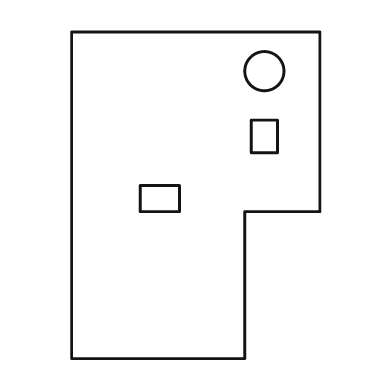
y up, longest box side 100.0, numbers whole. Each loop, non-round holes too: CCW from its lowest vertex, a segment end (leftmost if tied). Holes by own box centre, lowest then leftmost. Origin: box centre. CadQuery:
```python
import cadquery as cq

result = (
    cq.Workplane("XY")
    .moveTo(-38.0, -50.0)
    .lineTo(15.0, -50.0)
    .lineTo(15.0, -5.0)
    .lineTo(38.0, -5.0)
    .lineTo(38.0, 50.0)
    .lineTo(-38.0, 50.0)
    .close()
    .moveTo(-17.0, -5.0)
    .lineTo(-5.0, -5.0)
    .lineTo(-5.0, 3.0)
    .lineTo(-17.0, 3.0)
    .close()
    .moveTo(17.0, 13.0)
    .lineTo(25.0, 13.0)
    .lineTo(25.0, 23.0)
    .lineTo(17.0, 23.0)
    .close()
    .moveTo(21.0, 38.0)
    .circle(6.0)
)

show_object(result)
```